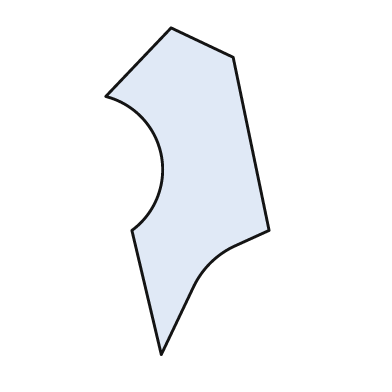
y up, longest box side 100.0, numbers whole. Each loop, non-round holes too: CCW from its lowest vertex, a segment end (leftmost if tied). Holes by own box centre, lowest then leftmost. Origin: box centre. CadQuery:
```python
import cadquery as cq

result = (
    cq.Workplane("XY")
    .moveTo(-8.0, -50.0)
    .lineTo(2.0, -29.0)
    .threePointArc((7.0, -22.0), (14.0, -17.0))
    .lineTo(25.0, -12.0)
    .lineTo(14.0, 41.0)
    .lineTo(-5.0, 50.0)
    .lineTo(-25.0, 29.0)
    .threePointArc((-8.0, 11.0), (-17.0, -12.0))
    .close()
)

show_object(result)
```